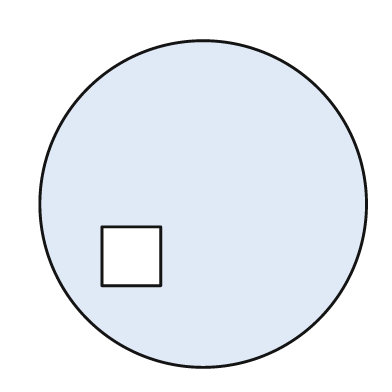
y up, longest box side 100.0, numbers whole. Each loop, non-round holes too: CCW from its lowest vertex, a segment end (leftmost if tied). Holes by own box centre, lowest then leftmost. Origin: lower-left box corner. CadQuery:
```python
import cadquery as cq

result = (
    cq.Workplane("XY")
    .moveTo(50.0, 50.0)
    .circle(50.0)
    .moveTo(19.0, 25.0)
    .lineTo(37.0, 25.0)
    .lineTo(37.0, 43.0)
    .lineTo(19.0, 43.0)
    .close()
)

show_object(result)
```